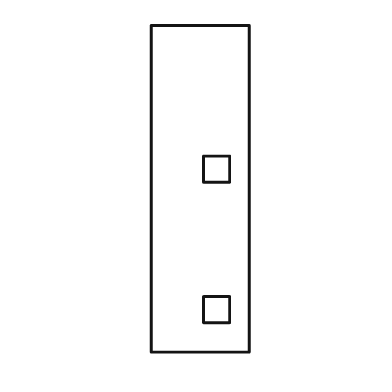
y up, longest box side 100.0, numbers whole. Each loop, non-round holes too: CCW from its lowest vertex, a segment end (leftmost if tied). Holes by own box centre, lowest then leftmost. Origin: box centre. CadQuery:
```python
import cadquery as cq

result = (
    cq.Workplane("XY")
    .moveTo(-15.0, -50.0)
    .lineTo(15.0, -50.0)
    .lineTo(15.0, 50.0)
    .lineTo(-15.0, 50.0)
    .close()
    .moveTo(1.0, -41.0)
    .lineTo(9.0, -41.0)
    .lineTo(9.0, -33.0)
    .lineTo(1.0, -33.0)
    .close()
    .moveTo(1.0, 2.0)
    .lineTo(9.0, 2.0)
    .lineTo(9.0, 10.0)
    .lineTo(1.0, 10.0)
    .close()
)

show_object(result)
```